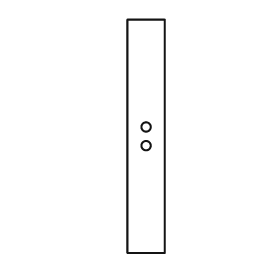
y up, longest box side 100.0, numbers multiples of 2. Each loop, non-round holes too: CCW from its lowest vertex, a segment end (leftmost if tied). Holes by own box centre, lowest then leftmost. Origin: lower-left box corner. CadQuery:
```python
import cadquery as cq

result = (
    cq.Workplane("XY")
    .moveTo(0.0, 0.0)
    .lineTo(16.0, 0.0)
    .lineTo(16.0, 100.0)
    .lineTo(0.0, 100.0)
    .close()
    .moveTo(8.0, 46.0)
    .circle(2.0)
    .moveTo(8.0, 54.0)
    .circle(2.0)
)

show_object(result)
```